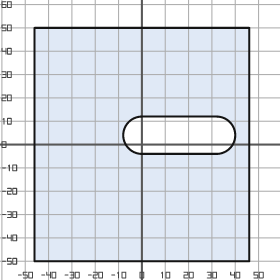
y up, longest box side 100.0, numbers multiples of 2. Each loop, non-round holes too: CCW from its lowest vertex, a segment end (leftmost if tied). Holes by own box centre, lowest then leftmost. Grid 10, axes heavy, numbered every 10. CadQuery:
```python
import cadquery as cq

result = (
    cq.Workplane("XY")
    .moveTo(-46.0, -50.0)
    .lineTo(46.0, -50.0)
    .lineTo(46.0, 50.0)
    .lineTo(-46.0, 50.0)
    .close()
    .moveTo(0.0, -4.0)
    .lineTo(32.0, -4.0)
    .threePointArc((40.0, 4.0), (32.0, 12.0))
    .lineTo(0.0, 12.0)
    .threePointArc((-8.0, 4.0), (0.0, -4.0))
    .close()
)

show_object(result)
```